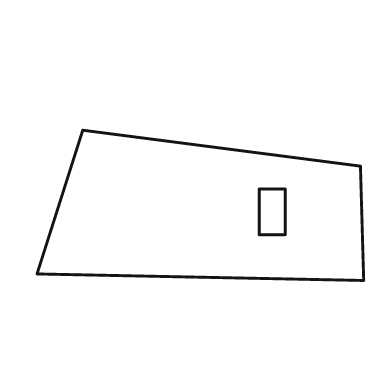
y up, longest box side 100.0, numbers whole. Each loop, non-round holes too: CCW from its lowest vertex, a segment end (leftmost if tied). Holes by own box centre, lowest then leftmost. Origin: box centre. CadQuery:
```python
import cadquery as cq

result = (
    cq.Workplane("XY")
    .moveTo(50.0, -23.0)
    .lineTo(49.0, 12.0)
    .lineTo(-36.0, 23.0)
    .lineTo(-50.0, -21.0)
    .close()
    .moveTo(18.0, -9.0)
    .lineTo(26.0, -9.0)
    .lineTo(26.0, 5.0)
    .lineTo(18.0, 5.0)
    .close()
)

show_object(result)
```